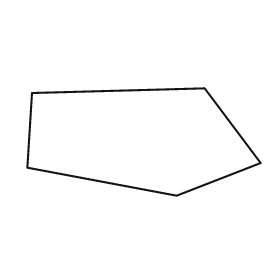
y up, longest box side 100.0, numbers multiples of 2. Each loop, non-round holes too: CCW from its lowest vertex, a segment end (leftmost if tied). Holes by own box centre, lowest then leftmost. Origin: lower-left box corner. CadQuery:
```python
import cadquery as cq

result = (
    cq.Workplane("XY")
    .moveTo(64.0, 0.0)
    .lineTo(100.0, 14.0)
    .lineTo(76.0, 46.0)
    .lineTo(2.0, 44.0)
    .lineTo(0.0, 12.0)
    .close()
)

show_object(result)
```